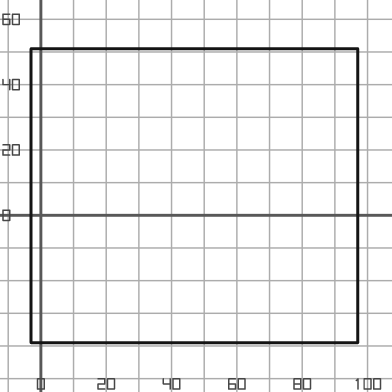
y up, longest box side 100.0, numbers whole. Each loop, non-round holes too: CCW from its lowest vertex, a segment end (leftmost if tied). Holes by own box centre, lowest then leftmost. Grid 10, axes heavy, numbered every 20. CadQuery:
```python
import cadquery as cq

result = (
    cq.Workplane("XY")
    .moveTo(-3.0, -39.0)
    .lineTo(97.0, -39.0)
    .lineTo(97.0, 51.0)
    .lineTo(-3.0, 51.0)
    .close()
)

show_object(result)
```